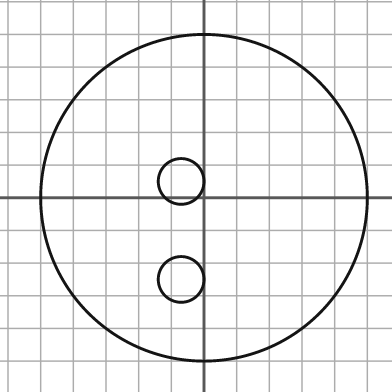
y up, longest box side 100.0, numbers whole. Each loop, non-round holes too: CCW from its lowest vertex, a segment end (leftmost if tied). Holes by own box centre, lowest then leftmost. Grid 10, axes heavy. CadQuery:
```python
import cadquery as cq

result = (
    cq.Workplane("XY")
    .moveTo(0.0, 0.0)
    .circle(50.0)
    .moveTo(-7.0, -25.0)
    .circle(7.0)
    .moveTo(-7.0, 5.0)
    .circle(7.0)
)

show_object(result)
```